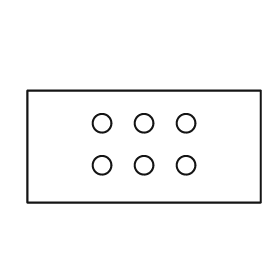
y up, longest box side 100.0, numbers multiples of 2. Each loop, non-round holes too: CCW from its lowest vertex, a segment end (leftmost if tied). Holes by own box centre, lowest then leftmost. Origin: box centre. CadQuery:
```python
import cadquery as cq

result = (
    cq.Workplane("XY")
    .moveTo(-50.0, -24.0)
    .lineTo(50.0, -24.0)
    .lineTo(50.0, 24.0)
    .lineTo(-50.0, 24.0)
    .close()
    .moveTo(-18.0, -8.0)
    .circle(4.0)
    .moveTo(0.0, -8.0)
    .circle(4.0)
    .moveTo(18.0, -8.0)
    .circle(4.0)
    .moveTo(-18.0, 10.0)
    .circle(4.0)
    .moveTo(0.0, 10.0)
    .circle(4.0)
    .moveTo(18.0, 10.0)
    .circle(4.0)
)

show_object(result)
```